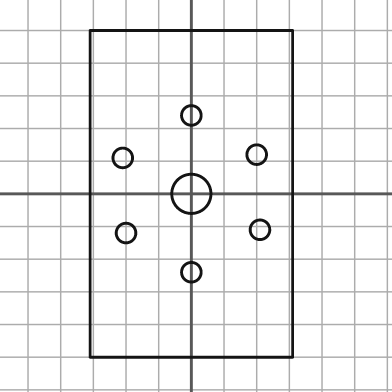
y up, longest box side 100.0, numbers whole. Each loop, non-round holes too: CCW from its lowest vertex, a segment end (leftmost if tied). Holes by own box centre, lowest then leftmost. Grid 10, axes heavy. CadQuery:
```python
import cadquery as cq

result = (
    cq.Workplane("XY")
    .moveTo(-31.0, -50.0)
    .lineTo(31.0, -50.0)
    .lineTo(31.0, 50.0)
    .lineTo(-31.0, 50.0)
    .close()
    .moveTo(0.0, -24.0)
    .circle(3.0)
    .moveTo(-20.0, -12.0)
    .circle(3.0)
    .moveTo(21.0, -11.0)
    .circle(3.0)
    .moveTo(0.0, 0.0)
    .circle(6.0)
    .moveTo(-21.0, 11.0)
    .circle(3.0)
    .moveTo(20.0, 12.0)
    .circle(3.0)
    .moveTo(0.0, 24.0)
    .circle(3.0)
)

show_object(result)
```